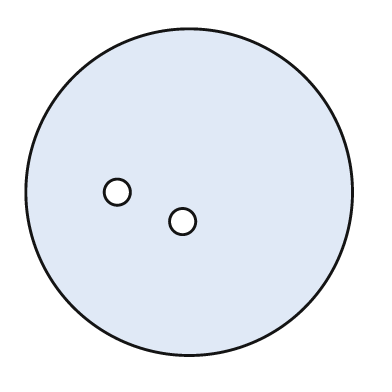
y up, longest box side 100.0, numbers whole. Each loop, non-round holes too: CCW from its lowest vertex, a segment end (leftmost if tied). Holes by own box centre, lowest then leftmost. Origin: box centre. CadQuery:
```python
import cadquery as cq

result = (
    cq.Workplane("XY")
    .moveTo(0.0, 0.0)
    .circle(50.0)
    .moveTo(-2.0, -9.0)
    .circle(4.0)
    .moveTo(-22.0, 0.0)
    .circle(4.0)
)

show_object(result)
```